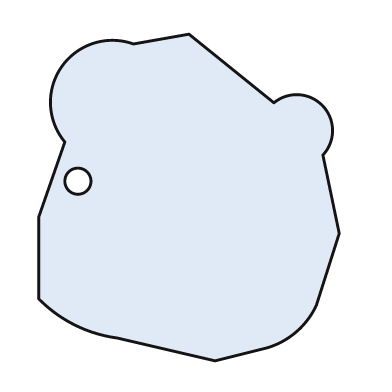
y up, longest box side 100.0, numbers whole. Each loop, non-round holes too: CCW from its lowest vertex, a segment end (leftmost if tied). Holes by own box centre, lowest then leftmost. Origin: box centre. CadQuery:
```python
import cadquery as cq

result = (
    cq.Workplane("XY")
    .moveTo(8.0, -50.0)
    .lineTo(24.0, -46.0)
    .threePointArc((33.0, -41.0), (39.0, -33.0))
    .lineTo(46.0, -11.0)
    .lineTo(41.0, 13.0)
    .threePointArc((41.0, 28.0), (26.0, 29.0))
    .lineTo(0.0, 50.0)
    .lineTo(-17.0, 47.0)
    .threePointArc((-39.0, 40.0), (-38.0, 17.0))
    .lineTo(-46.0, -6.0)
    .lineTo(-46.0, -31.0)
    .threePointArc((-35.0, -39.0), (-22.0, -43.0))
    .close()
    .moveTo(-34.0, 5.0)
    .circle(4.0)
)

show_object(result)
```